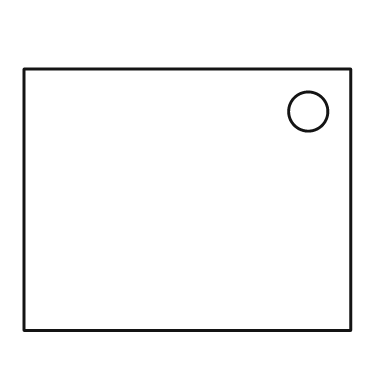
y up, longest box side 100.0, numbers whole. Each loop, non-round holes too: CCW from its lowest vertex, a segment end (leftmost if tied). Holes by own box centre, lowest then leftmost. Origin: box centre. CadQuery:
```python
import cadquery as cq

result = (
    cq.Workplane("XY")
    .moveTo(-50.0, -40.0)
    .lineTo(50.0, -40.0)
    .lineTo(50.0, 40.0)
    .lineTo(-50.0, 40.0)
    .close()
    .moveTo(37.0, 27.0)
    .circle(6.0)
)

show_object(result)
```